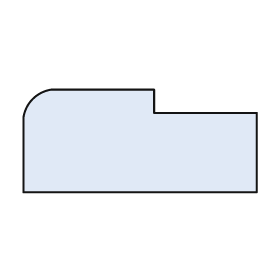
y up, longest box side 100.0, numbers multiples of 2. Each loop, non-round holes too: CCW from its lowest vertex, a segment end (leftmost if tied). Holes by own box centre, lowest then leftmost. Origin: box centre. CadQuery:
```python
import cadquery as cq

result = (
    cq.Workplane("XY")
    .moveTo(-50.0, -22.0)
    .lineTo(50.0, -22.0)
    .lineTo(50.0, 12.0)
    .lineTo(6.0, 12.0)
    .lineTo(6.0, 22.0)
    .lineTo(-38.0, 22.0)
    .threePointArc((-46.0, 18.0), (-50.0, 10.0))
    .close()
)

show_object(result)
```